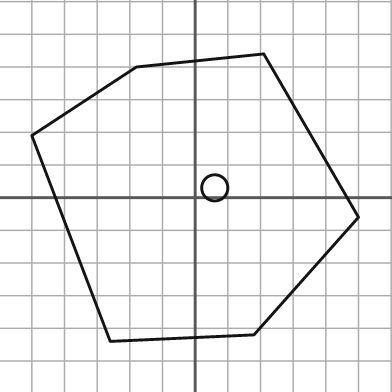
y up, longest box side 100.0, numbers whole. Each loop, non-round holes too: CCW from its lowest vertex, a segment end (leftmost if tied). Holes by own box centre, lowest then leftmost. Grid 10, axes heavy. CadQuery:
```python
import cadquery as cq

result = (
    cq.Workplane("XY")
    .moveTo(-26.0, -44.0)
    .lineTo(18.0, -42.0)
    .lineTo(50.0, -6.0)
    .lineTo(21.0, 44.0)
    .lineTo(-18.0, 40.0)
    .lineTo(-50.0, 19.0)
    .close()
    .moveTo(6.0, 3.0)
    .circle(4.0)
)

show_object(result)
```